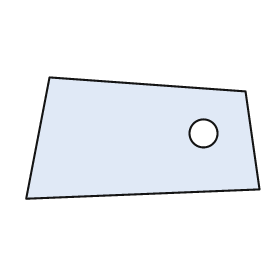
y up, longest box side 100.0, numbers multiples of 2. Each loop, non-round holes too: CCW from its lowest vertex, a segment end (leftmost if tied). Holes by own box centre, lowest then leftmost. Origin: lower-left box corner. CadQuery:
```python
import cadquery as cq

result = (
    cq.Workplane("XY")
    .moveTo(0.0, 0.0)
    .lineTo(100.0, 4.0)
    .lineTo(94.0, 46.0)
    .lineTo(10.0, 52.0)
    .close()
    .moveTo(76.0, 28.0)
    .circle(6.0)
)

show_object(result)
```